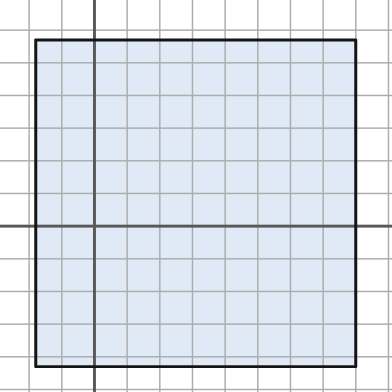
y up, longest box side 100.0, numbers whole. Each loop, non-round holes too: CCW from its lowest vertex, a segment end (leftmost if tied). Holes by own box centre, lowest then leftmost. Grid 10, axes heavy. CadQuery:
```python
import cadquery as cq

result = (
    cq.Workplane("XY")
    .moveTo(-18.0, -43.0)
    .lineTo(80.0, -43.0)
    .lineTo(80.0, 57.0)
    .lineTo(-18.0, 57.0)
    .close()
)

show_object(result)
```